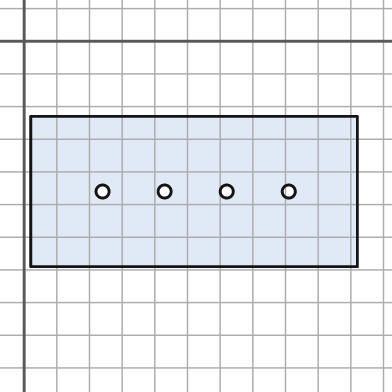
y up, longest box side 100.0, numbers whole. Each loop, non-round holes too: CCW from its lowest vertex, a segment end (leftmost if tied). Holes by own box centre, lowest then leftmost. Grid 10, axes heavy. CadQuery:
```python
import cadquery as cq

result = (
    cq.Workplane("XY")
    .moveTo(2.0, -69.0)
    .lineTo(102.0, -69.0)
    .lineTo(102.0, -23.0)
    .lineTo(2.0, -23.0)
    .close()
    .moveTo(24.0, -46.0)
    .circle(2.0)
    .moveTo(43.0, -46.0)
    .circle(2.0)
    .moveTo(62.0, -46.0)
    .circle(2.0)
    .moveTo(81.0, -46.0)
    .circle(2.0)
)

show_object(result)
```